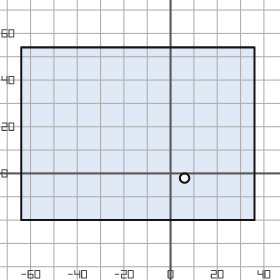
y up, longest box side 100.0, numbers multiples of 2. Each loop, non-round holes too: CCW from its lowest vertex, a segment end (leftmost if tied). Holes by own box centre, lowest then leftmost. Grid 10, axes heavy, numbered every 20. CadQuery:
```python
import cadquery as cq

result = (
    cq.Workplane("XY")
    .moveTo(-64.0, -20.0)
    .lineTo(36.0, -20.0)
    .lineTo(36.0, 54.0)
    .lineTo(-64.0, 54.0)
    .close()
    .moveTo(6.0, -2.0)
    .circle(2.0)
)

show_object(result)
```